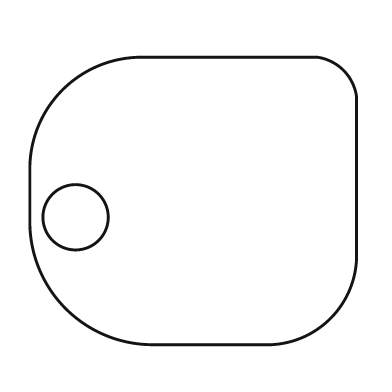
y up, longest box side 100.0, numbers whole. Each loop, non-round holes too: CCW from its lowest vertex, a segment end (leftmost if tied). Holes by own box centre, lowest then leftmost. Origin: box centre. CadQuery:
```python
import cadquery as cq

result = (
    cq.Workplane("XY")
    .moveTo(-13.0, -44.0)
    .lineTo(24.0, -44.0)
    .threePointArc((42.0, -36.0), (50.0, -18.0))
    .lineTo(50.0, 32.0)
    .threePointArc((46.0, 40.0), (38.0, 44.0))
    .lineTo(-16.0, 44.0)
    .threePointArc((-40.0, 34.0), (-50.0, 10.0))
    .lineTo(-50.0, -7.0)
    .threePointArc((-39.0, -33.0), (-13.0, -44.0))
    .close()
    .moveTo(-36.0, -5.0)
    .circle(10.0)
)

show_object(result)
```